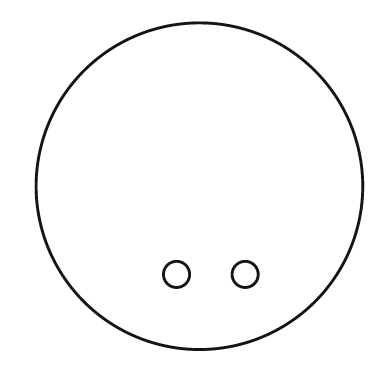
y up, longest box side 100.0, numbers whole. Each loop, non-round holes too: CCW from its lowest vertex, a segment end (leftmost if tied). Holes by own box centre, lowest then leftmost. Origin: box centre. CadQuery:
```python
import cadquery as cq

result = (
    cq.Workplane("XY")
    .moveTo(0.0, 0.0)
    .circle(50.0)
    .moveTo(-7.0, -27.0)
    .circle(4.0)
    .moveTo(14.0, -27.0)
    .circle(4.0)
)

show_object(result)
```